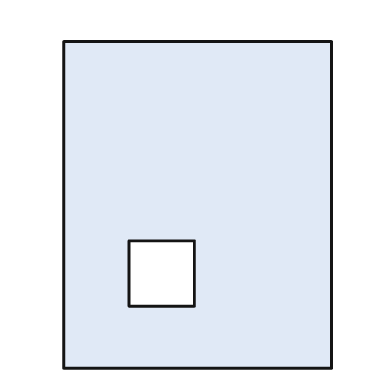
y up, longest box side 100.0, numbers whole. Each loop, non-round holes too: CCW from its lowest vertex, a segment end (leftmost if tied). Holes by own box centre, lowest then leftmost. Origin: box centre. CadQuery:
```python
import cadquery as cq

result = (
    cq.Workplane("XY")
    .moveTo(-41.0, -50.0)
    .lineTo(41.0, -50.0)
    .lineTo(41.0, 50.0)
    .lineTo(-41.0, 50.0)
    .close()
    .moveTo(-21.0, -31.0)
    .lineTo(-1.0, -31.0)
    .lineTo(-1.0, -11.0)
    .lineTo(-21.0, -11.0)
    .close()
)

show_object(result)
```